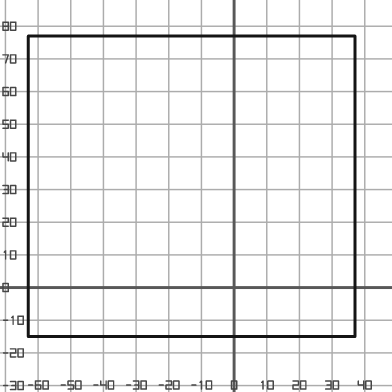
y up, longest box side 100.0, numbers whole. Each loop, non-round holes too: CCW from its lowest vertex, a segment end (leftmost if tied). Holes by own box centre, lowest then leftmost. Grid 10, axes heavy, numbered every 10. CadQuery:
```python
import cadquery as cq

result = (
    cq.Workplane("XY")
    .moveTo(-63.0, -15.0)
    .lineTo(37.0, -15.0)
    .lineTo(37.0, 77.0)
    .lineTo(-63.0, 77.0)
    .close()
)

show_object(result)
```